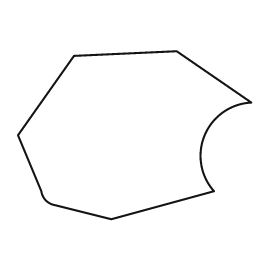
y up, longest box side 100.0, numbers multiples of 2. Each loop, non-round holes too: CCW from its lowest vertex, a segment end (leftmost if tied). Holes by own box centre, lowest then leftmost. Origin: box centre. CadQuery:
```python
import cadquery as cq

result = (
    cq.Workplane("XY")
    .moveTo(-10.0, -36.0)
    .lineTo(34.0, -24.0)
    .threePointArc((30.0, 0.0), (50.0, 14.0))
    .lineTo(18.0, 36.0)
    .lineTo(-26.0, 34.0)
    .lineTo(-50.0, 0.0)
    .lineTo(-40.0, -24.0)
    .threePointArc((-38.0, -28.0), (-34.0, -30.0))
    .close()
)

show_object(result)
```